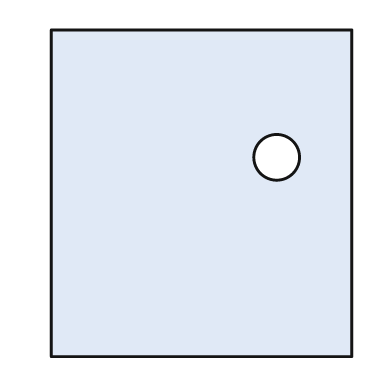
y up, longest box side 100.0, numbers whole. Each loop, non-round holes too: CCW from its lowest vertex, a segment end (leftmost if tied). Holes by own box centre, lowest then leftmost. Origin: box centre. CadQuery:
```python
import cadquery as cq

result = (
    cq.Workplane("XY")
    .moveTo(-46.0, -50.0)
    .lineTo(46.0, -50.0)
    .lineTo(46.0, 50.0)
    .lineTo(-46.0, 50.0)
    .close()
    .moveTo(23.0, 11.0)
    .circle(7.0)
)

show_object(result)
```